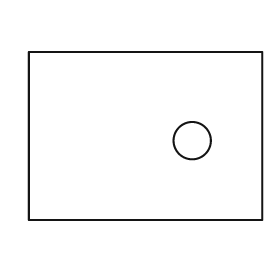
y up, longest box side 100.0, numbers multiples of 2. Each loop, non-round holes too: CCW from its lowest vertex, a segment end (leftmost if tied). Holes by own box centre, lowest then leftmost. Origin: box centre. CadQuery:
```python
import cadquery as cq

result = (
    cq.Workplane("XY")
    .moveTo(-50.0, -36.0)
    .lineTo(50.0, -36.0)
    .lineTo(50.0, 36.0)
    .lineTo(-50.0, 36.0)
    .close()
    .moveTo(20.0, -2.0)
    .circle(8.0)
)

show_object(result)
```